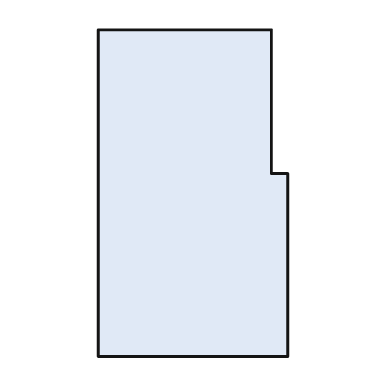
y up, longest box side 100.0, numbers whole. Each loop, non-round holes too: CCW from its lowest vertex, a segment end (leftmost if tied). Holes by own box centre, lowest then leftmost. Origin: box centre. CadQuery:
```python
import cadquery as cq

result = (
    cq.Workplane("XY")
    .moveTo(-29.0, -50.0)
    .lineTo(29.0, -50.0)
    .lineTo(29.0, 6.0)
    .lineTo(24.0, 6.0)
    .lineTo(24.0, 50.0)
    .lineTo(-29.0, 50.0)
    .close()
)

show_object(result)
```